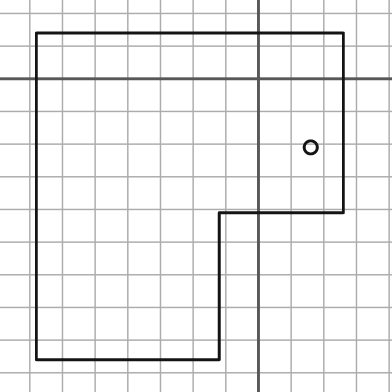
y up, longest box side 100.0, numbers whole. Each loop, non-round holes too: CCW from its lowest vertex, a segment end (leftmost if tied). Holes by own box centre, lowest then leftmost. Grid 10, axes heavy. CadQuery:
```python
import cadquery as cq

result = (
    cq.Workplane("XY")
    .moveTo(-68.0, -86.0)
    .lineTo(-12.0, -86.0)
    .lineTo(-12.0, -41.0)
    .lineTo(26.0, -41.0)
    .lineTo(26.0, 14.0)
    .lineTo(-68.0, 14.0)
    .close()
    .moveTo(16.0, -21.0)
    .circle(2.0)
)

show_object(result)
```